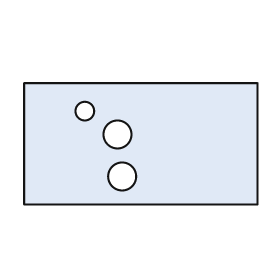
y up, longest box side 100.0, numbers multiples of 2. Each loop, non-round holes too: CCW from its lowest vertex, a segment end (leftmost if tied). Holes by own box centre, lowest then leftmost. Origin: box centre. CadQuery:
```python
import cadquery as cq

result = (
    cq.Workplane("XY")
    .moveTo(-50.0, -26.0)
    .lineTo(50.0, -26.0)
    .lineTo(50.0, 26.0)
    .lineTo(-50.0, 26.0)
    .close()
    .moveTo(-8.0, -14.0)
    .circle(6.0)
    .moveTo(-10.0, 4.0)
    .circle(6.0)
    .moveTo(-24.0, 14.0)
    .circle(4.0)
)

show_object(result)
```